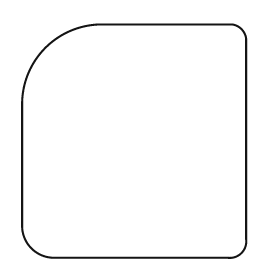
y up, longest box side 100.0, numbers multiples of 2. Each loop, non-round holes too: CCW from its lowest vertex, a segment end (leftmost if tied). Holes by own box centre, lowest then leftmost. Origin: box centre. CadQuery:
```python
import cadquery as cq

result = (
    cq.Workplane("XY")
    .moveTo(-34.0, -50.0)
    .lineTo(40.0, -50.0)
    .threePointArc((46.0, -48.0), (48.0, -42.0))
    .lineTo(48.0, 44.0)
    .threePointArc((46.0, 48.0), (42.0, 50.0))
    .lineTo(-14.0, 50.0)
    .threePointArc((-38.0, 40.0), (-48.0, 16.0))
    .lineTo(-48.0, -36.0)
    .threePointArc((-44.0, -46.0), (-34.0, -50.0))
    .close()
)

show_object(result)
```